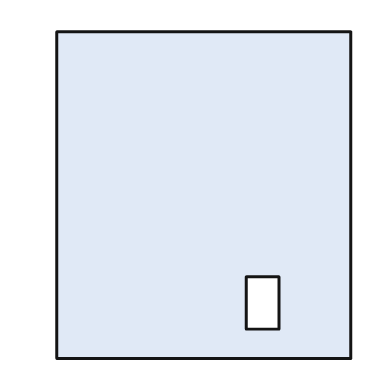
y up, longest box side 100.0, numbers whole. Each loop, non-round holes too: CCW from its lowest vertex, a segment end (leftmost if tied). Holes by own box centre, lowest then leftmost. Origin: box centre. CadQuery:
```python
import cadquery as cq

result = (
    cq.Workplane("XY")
    .moveTo(-45.0, -50.0)
    .lineTo(45.0, -50.0)
    .lineTo(45.0, 50.0)
    .lineTo(-45.0, 50.0)
    .close()
    .moveTo(13.0, -41.0)
    .lineTo(23.0, -41.0)
    .lineTo(23.0, -25.0)
    .lineTo(13.0, -25.0)
    .close()
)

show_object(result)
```